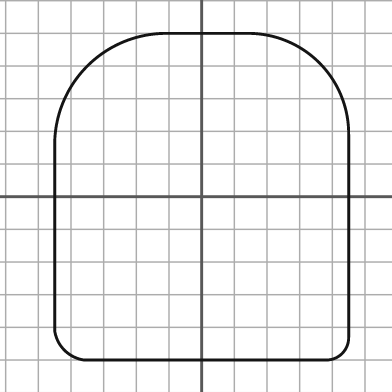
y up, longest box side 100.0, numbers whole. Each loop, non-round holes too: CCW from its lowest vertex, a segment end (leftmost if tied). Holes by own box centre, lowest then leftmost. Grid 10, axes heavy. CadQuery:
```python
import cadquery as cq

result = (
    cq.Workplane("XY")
    .moveTo(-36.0, -50.0)
    .lineTo(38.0, -50.0)
    .threePointArc((43.0, -48.0), (45.0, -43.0))
    .lineTo(45.0, 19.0)
    .threePointArc((36.0, 41.0), (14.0, 50.0))
    .lineTo(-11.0, 50.0)
    .threePointArc((-35.0, 40.0), (-45.0, 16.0))
    .lineTo(-45.0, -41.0)
    .threePointArc((-42.0, -47.0), (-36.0, -50.0))
    .close()
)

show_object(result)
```